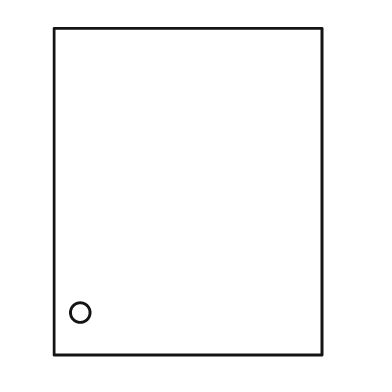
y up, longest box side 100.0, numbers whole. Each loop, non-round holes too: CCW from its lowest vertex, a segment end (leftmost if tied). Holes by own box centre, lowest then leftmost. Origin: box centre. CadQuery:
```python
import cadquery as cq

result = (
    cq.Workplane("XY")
    .moveTo(-41.0, -50.0)
    .lineTo(41.0, -50.0)
    .lineTo(41.0, 50.0)
    .lineTo(-41.0, 50.0)
    .close()
    .moveTo(-33.0, -37.0)
    .circle(3.0)
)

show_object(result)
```